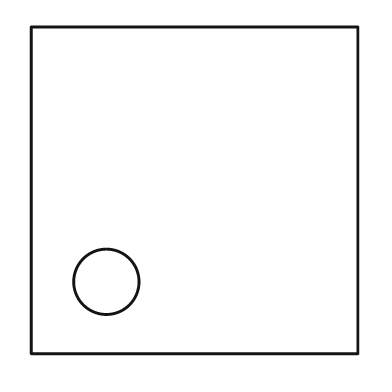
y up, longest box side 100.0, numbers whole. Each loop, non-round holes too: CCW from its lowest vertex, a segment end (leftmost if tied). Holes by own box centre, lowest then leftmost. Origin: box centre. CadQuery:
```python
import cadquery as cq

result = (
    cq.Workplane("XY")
    .moveTo(-50.0, -50.0)
    .lineTo(50.0, -50.0)
    .lineTo(50.0, 50.0)
    .lineTo(-50.0, 50.0)
    .close()
    .moveTo(-27.0, -28.0)
    .circle(10.0)
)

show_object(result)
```